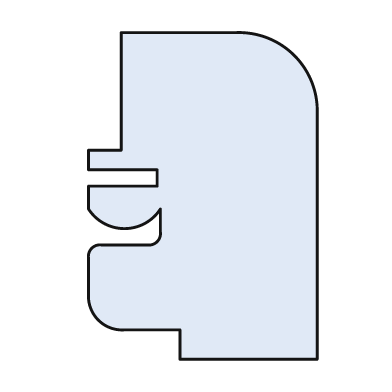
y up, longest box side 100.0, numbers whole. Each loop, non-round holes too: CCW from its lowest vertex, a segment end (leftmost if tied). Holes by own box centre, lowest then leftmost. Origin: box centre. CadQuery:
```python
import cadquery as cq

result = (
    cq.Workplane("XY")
    .moveTo(-7.0, -50.0)
    .lineTo(35.0, -50.0)
    .lineTo(35.0, 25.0)
    .threePointArc((28.0, 43.0), (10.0, 50.0))
    .lineTo(-25.0, 50.0)
    .lineTo(-25.0, 14.0)
    .lineTo(-35.0, 14.0)
    .lineTo(-35.0, 8.0)
    .lineTo(-14.0, 8.0)
    .lineTo(-14.0, 3.0)
    .lineTo(-35.0, 3.0)
    .lineTo(-35.0, -4.0)
    .threePointArc((-24.0, -10.0), (-13.0, -4.0))
    .lineTo(-13.0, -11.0)
    .threePointArc((-14.0, -14.0), (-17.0, -15.0))
    .lineTo(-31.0, -15.0)
    .threePointArc((-34.0, -16.0), (-35.0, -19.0))
    .lineTo(-35.0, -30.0)
    .threePointArc((-32.0, -38.0), (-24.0, -41.0))
    .lineTo(-7.0, -41.0)
    .close()
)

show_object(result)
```